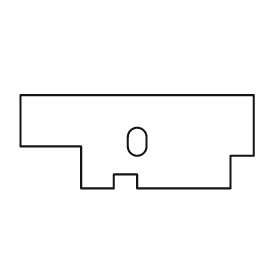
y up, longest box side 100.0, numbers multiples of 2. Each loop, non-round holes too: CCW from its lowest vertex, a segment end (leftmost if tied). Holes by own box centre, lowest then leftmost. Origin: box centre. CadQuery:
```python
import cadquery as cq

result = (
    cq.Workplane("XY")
    .moveTo(-24.0, -20.0)
    .lineTo(-10.0, -20.0)
    .lineTo(-10.0, -14.0)
    .lineTo(0.0, -14.0)
    .lineTo(0.0, -20.0)
    .lineTo(40.0, -20.0)
    .lineTo(40.0, -6.0)
    .lineTo(50.0, -6.0)
    .lineTo(50.0, 20.0)
    .lineTo(-50.0, 20.0)
    .lineTo(-50.0, -2.0)
    .lineTo(-24.0, -2.0)
    .close()
    .moveTo(-4.0, -2.0)
    .threePointArc((0.0, -6.0), (4.0, -2.0))
    .lineTo(4.0, 2.0)
    .threePointArc((0.0, 6.0), (-4.0, 2.0))
    .close()
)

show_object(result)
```